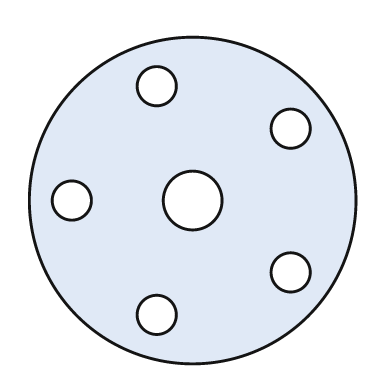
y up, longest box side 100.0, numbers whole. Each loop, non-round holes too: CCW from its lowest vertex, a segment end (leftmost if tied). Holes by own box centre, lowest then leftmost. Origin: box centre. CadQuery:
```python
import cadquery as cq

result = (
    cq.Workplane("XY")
    .moveTo(0.0, 0.0)
    .circle(50.0)
    .moveTo(-11.0, -35.0)
    .circle(6.0)
    .moveTo(30.0, -22.0)
    .circle(6.0)
    .moveTo(-37.0, 0.0)
    .circle(6.0)
    .moveTo(0.0, 0.0)
    .circle(9.0)
    .moveTo(30.0, 22.0)
    .circle(6.0)
    .moveTo(-11.0, 35.0)
    .circle(6.0)
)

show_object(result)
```